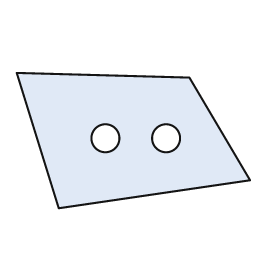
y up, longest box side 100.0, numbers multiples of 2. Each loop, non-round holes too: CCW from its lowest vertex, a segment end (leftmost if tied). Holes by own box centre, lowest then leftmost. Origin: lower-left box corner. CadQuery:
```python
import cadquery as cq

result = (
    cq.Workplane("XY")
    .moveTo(18.0, 0.0)
    .lineTo(100.0, 12.0)
    .lineTo(74.0, 56.0)
    .lineTo(0.0, 58.0)
    .close()
    .moveTo(38.0, 30.0)
    .circle(6.0)
    .moveTo(64.0, 30.0)
    .circle(6.0)
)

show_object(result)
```